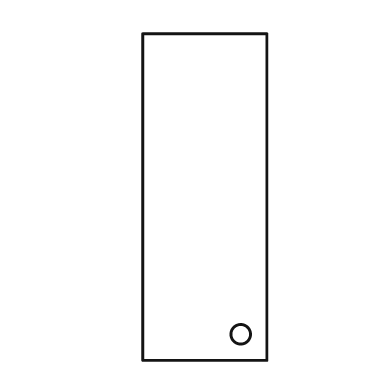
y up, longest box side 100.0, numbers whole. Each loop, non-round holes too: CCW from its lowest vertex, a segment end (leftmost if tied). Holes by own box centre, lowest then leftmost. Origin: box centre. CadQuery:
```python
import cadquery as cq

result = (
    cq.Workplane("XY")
    .moveTo(-19.0, -50.0)
    .lineTo(19.0, -50.0)
    .lineTo(19.0, 50.0)
    .lineTo(-19.0, 50.0)
    .close()
    .moveTo(11.0, -42.0)
    .circle(3.0)
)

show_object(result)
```